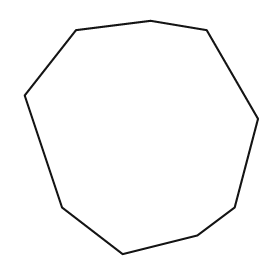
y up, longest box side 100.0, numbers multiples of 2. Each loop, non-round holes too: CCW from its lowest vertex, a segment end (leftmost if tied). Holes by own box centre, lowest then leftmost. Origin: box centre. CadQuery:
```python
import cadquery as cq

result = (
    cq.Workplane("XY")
    .moveTo(-8.0, -50.0)
    .lineTo(24.0, -42.0)
    .lineTo(40.0, -30.0)
    .lineTo(50.0, 8.0)
    .lineTo(28.0, 46.0)
    .lineTo(4.0, 50.0)
    .lineTo(-28.0, 46.0)
    .lineTo(-50.0, 18.0)
    .lineTo(-34.0, -30.0)
    .close()
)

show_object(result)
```